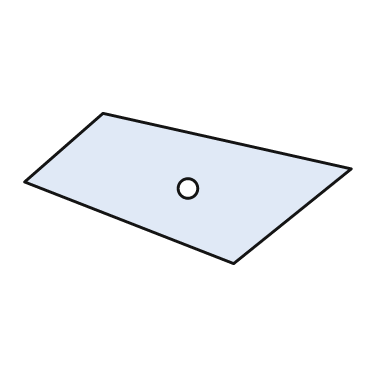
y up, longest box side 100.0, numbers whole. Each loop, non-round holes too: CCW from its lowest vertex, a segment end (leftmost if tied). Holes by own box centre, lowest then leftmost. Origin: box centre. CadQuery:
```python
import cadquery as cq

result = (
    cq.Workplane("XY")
    .moveTo(14.0, -23.0)
    .lineTo(50.0, 6.0)
    .lineTo(-26.0, 23.0)
    .lineTo(-50.0, 2.0)
    .close()
    .moveTo(0.0, 0.0)
    .circle(3.0)
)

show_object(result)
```